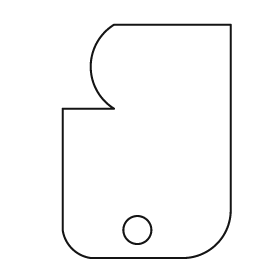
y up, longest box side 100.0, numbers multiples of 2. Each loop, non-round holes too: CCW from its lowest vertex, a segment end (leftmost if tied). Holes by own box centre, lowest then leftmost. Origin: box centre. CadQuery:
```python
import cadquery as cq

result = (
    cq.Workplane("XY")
    .moveTo(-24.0, -50.0)
    .lineTo(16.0, -50.0)
    .threePointArc((30.0, -44.0), (36.0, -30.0))
    .lineTo(36.0, 50.0)
    .lineTo(-14.0, 50.0)
    .threePointArc((-24.0, 32.0), (-14.0, 14.0))
    .lineTo(-36.0, 14.0)
    .lineTo(-36.0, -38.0)
    .threePointArc((-32.0, -46.0), (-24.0, -50.0))
    .close()
    .moveTo(-4.0, -38.0)
    .circle(6.0)
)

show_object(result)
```